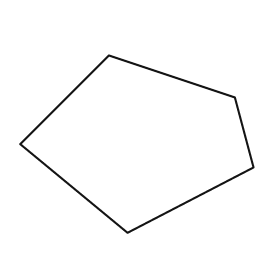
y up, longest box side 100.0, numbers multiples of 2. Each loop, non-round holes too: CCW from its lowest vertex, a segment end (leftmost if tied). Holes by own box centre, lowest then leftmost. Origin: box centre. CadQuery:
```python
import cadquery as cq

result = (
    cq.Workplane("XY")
    .moveTo(-4.0, -38.0)
    .lineTo(50.0, -10.0)
    .lineTo(42.0, 20.0)
    .lineTo(-12.0, 38.0)
    .lineTo(-50.0, 0.0)
    .close()
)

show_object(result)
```